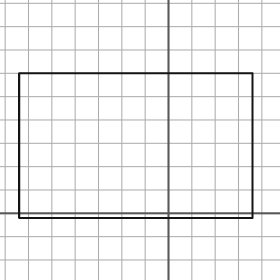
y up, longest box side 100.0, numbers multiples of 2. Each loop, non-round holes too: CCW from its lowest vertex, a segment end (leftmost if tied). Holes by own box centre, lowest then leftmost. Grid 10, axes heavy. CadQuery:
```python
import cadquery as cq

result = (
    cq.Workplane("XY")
    .moveTo(-64.0, -2.0)
    .lineTo(36.0, -2.0)
    .lineTo(36.0, 60.0)
    .lineTo(-64.0, 60.0)
    .close()
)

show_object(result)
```